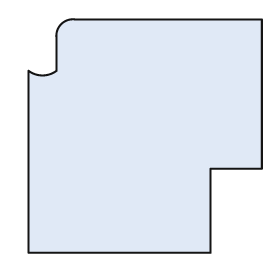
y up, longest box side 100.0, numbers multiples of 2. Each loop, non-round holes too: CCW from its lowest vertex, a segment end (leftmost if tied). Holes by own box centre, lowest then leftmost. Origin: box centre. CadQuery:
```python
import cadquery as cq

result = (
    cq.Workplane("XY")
    .moveTo(-50.0, -50.0)
    .lineTo(28.0, -50.0)
    .lineTo(28.0, -14.0)
    .lineTo(50.0, -14.0)
    .lineTo(50.0, 50.0)
    .lineTo(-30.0, 50.0)
    .threePointArc((-36.0, 48.0), (-38.0, 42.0))
    .lineTo(-38.0, 28.0)
    .threePointArc((-44.0, 26.0), (-50.0, 28.0))
    .close()
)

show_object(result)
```